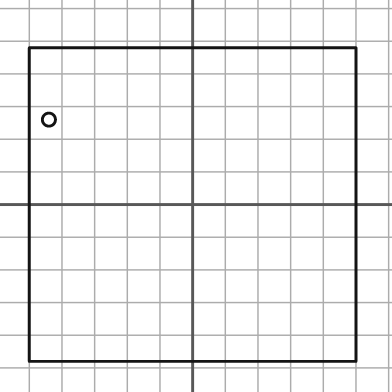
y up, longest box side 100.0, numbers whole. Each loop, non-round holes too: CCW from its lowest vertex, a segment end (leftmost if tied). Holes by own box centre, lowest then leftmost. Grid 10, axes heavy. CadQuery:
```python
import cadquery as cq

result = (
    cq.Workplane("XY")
    .moveTo(-50.0, -48.0)
    .lineTo(50.0, -48.0)
    .lineTo(50.0, 48.0)
    .lineTo(-50.0, 48.0)
    .close()
    .moveTo(-44.0, 26.0)
    .circle(2.0)
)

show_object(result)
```